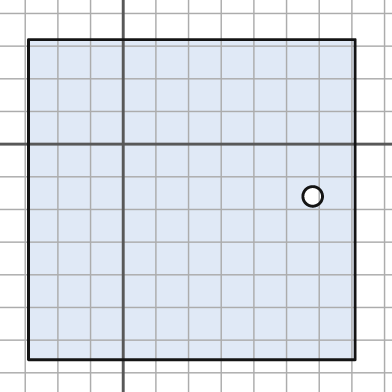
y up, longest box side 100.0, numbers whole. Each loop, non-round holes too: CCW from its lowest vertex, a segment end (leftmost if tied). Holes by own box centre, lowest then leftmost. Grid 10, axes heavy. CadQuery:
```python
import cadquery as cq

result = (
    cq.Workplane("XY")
    .moveTo(-29.0, -66.0)
    .lineTo(71.0, -66.0)
    .lineTo(71.0, 32.0)
    .lineTo(-29.0, 32.0)
    .close()
    .moveTo(58.0, -16.0)
    .circle(3.0)
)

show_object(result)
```